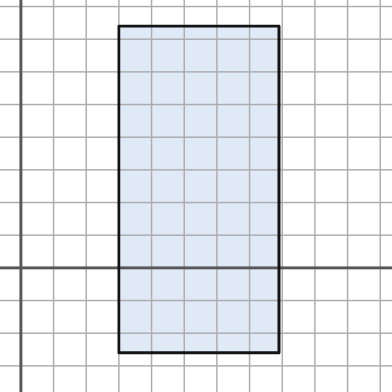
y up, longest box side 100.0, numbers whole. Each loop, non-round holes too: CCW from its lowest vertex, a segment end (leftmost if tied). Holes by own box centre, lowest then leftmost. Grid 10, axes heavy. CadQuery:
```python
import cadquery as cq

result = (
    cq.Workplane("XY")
    .moveTo(30.0, -26.0)
    .lineTo(79.0, -26.0)
    .lineTo(79.0, 74.0)
    .lineTo(30.0, 74.0)
    .close()
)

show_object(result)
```